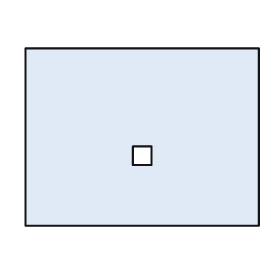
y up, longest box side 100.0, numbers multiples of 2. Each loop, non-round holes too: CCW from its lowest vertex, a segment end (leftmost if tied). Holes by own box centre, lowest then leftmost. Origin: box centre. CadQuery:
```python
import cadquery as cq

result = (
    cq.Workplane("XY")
    .moveTo(-50.0, -38.0)
    .lineTo(50.0, -38.0)
    .lineTo(50.0, 38.0)
    .lineTo(-50.0, 38.0)
    .close()
    .moveTo(-4.0, -12.0)
    .lineTo(4.0, -12.0)
    .lineTo(4.0, -4.0)
    .lineTo(-4.0, -4.0)
    .close()
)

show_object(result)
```